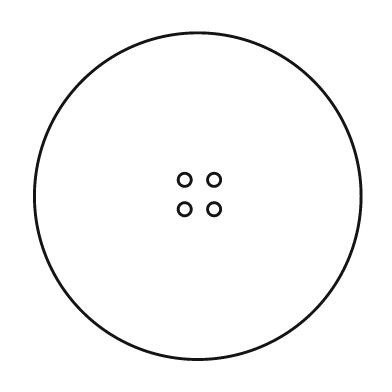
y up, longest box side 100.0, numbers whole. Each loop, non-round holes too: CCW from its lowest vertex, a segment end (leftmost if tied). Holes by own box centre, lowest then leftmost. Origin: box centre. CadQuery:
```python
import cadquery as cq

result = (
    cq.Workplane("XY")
    .moveTo(0.0, 0.0)
    .circle(50.0)
    .moveTo(-4.0, -4.0)
    .circle(2.0)
    .moveTo(5.0, -4.0)
    .circle(2.0)
    .moveTo(-4.0, 5.0)
    .circle(2.0)
    .moveTo(5.0, 5.0)
    .circle(2.0)
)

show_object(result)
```